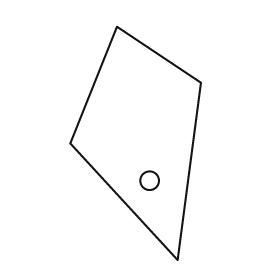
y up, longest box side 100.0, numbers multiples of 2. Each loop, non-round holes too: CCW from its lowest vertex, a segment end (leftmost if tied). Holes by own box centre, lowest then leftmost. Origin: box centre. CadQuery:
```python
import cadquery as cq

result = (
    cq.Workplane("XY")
    .moveTo(18.0, -50.0)
    .lineTo(28.0, 26.0)
    .lineTo(-8.0, 50.0)
    .lineTo(-28.0, 0.0)
    .close()
    .moveTo(6.0, -16.0)
    .circle(4.0)
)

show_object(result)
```